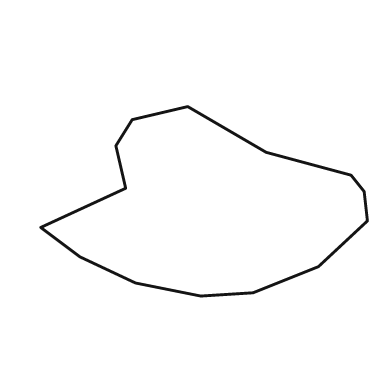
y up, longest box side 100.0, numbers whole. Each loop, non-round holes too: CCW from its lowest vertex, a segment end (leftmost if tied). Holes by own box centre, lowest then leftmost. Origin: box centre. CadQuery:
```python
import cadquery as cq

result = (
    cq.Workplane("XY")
    .moveTo(-1.0, -29.0)
    .lineTo(15.0, -28.0)
    .lineTo(35.0, -20.0)
    .lineTo(50.0, -6.0)
    .lineTo(49.0, 3.0)
    .lineTo(45.0, 8.0)
    .lineTo(19.0, 15.0)
    .lineTo(-5.0, 29.0)
    .lineTo(-22.0, 25.0)
    .lineTo(-27.0, 17.0)
    .lineTo(-24.0, 4.0)
    .lineTo(-50.0, -8.0)
    .lineTo(-38.0, -17.0)
    .lineTo(-21.0, -25.0)
    .close()
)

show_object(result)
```